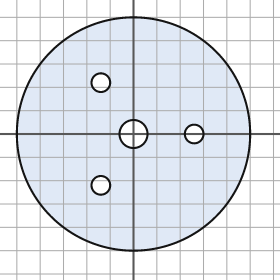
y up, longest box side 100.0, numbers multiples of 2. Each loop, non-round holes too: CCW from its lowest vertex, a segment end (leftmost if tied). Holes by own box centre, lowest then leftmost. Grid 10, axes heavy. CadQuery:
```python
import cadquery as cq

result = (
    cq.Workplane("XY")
    .moveTo(0.0, 0.0)
    .circle(50.0)
    .moveTo(-14.0, -22.0)
    .circle(4.0)
    .moveTo(0.0, 0.0)
    .circle(6.0)
    .moveTo(26.0, 0.0)
    .circle(4.0)
    .moveTo(-14.0, 22.0)
    .circle(4.0)
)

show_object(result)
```